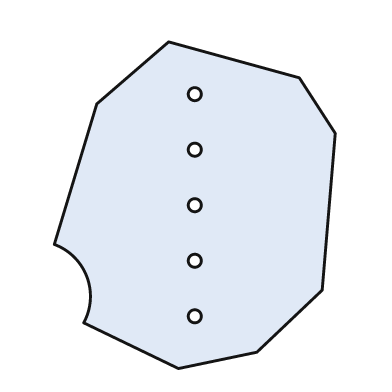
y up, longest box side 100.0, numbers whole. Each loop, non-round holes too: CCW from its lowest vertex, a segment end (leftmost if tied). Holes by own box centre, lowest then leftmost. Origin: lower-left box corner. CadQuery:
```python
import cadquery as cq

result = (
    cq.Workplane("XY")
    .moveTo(38.0, 0.0)
    .lineTo(62.0, 5.0)
    .lineTo(82.0, 24.0)
    .lineTo(86.0, 72.0)
    .lineTo(75.0, 89.0)
    .lineTo(35.0, 100.0)
    .lineTo(13.0, 81.0)
    .lineTo(0.0, 38.0)
    .threePointArc((10.0, 28.0), (9.0, 14.0))
    .close()
    .moveTo(43.0, 16.0)
    .circle(2.0)
    .moveTo(43.0, 33.0)
    .circle(2.0)
    .moveTo(43.0, 50.0)
    .circle(2.0)
    .moveTo(43.0, 67.0)
    .circle(2.0)
    .moveTo(43.0, 84.0)
    .circle(2.0)
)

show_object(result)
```